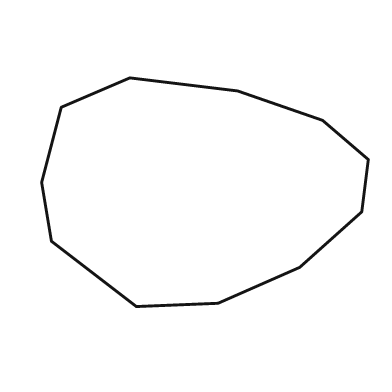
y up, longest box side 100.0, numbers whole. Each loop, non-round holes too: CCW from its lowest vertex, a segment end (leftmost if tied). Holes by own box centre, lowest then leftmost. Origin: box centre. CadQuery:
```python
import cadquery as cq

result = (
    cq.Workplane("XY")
    .moveTo(-21.0, -35.0)
    .lineTo(4.0, -34.0)
    .lineTo(29.0, -23.0)
    .lineTo(48.0, -6.0)
    .lineTo(50.0, 10.0)
    .lineTo(36.0, 22.0)
    .lineTo(10.0, 31.0)
    .lineTo(-23.0, 35.0)
    .lineTo(-44.0, 26.0)
    .lineTo(-50.0, 3.0)
    .lineTo(-47.0, -15.0)
    .close()
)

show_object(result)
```